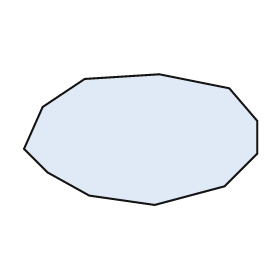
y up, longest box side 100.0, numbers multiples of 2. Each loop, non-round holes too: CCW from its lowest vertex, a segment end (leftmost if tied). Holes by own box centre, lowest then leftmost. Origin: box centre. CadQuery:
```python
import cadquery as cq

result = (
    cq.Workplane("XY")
    .moveTo(6.0, -28.0)
    .lineTo(36.0, -20.0)
    .lineTo(50.0, -6.0)
    .lineTo(50.0, 8.0)
    .lineTo(38.0, 22.0)
    .lineTo(8.0, 28.0)
    .lineTo(-24.0, 26.0)
    .lineTo(-42.0, 14.0)
    .lineTo(-50.0, -4.0)
    .lineTo(-40.0, -14.0)
    .lineTo(-22.0, -24.0)
    .close()
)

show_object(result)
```